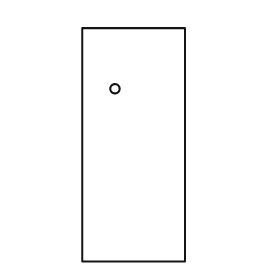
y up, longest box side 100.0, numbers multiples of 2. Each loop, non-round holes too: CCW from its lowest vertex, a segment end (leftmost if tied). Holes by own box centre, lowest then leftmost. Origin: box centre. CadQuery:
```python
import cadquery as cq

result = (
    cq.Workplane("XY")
    .moveTo(-22.0, -50.0)
    .lineTo(22.0, -50.0)
    .lineTo(22.0, 50.0)
    .lineTo(-22.0, 50.0)
    .close()
    .moveTo(-8.0, 24.0)
    .circle(2.0)
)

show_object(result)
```